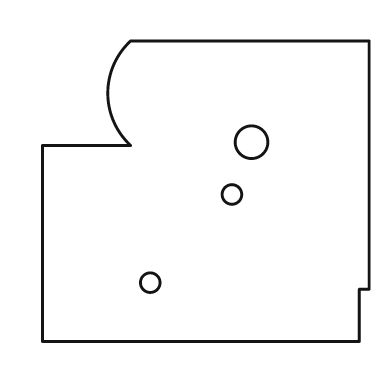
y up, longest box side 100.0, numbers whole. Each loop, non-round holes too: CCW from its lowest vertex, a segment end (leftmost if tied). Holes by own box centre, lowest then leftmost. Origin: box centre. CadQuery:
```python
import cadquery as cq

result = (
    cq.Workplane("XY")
    .moveTo(-50.0, -46.0)
    .lineTo(47.0, -46.0)
    .lineTo(47.0, -30.0)
    .lineTo(50.0, -30.0)
    .lineTo(50.0, 46.0)
    .lineTo(-23.0, 46.0)
    .threePointArc((-30.0, 30.0), (-23.0, 14.0))
    .lineTo(-50.0, 14.0)
    .close()
    .moveTo(-17.0, -28.0)
    .circle(3.0)
    .moveTo(8.0, -1.0)
    .circle(3.0)
    .moveTo(14.0, 15.0)
    .circle(5.0)
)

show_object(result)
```